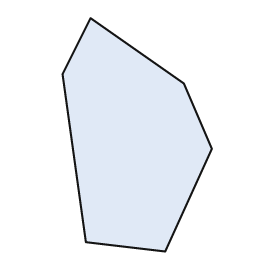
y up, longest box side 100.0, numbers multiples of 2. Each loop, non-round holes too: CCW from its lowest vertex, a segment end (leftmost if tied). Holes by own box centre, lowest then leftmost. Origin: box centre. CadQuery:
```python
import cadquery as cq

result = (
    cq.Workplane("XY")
    .moveTo(12.0, -50.0)
    .lineTo(32.0, -6.0)
    .lineTo(20.0, 22.0)
    .lineTo(-20.0, 50.0)
    .lineTo(-32.0, 26.0)
    .lineTo(-22.0, -46.0)
    .close()
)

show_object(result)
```